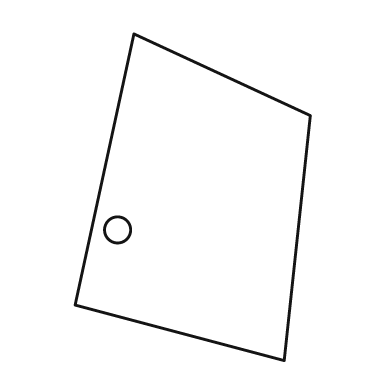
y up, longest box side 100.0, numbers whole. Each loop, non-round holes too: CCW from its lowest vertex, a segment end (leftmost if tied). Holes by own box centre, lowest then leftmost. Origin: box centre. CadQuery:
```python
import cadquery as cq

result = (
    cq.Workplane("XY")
    .moveTo(28.0, -50.0)
    .lineTo(36.0, 25.0)
    .lineTo(-18.0, 50.0)
    .lineTo(-36.0, -33.0)
    .close()
    .moveTo(-23.0, -10.0)
    .circle(4.0)
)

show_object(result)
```